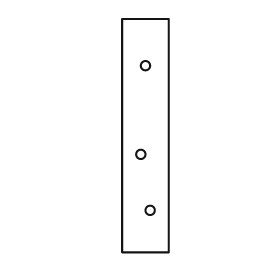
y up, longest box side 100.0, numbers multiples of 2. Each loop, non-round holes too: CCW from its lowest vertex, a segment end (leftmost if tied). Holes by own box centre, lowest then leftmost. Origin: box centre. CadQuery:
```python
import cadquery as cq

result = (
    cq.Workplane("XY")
    .moveTo(-10.0, -50.0)
    .lineTo(10.0, -50.0)
    .lineTo(10.0, 50.0)
    .lineTo(-10.0, 50.0)
    .close()
    .moveTo(2.0, -32.0)
    .circle(2.0)
    .moveTo(-2.0, -8.0)
    .circle(2.0)
    .moveTo(0.0, 30.0)
    .circle(2.0)
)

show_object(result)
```